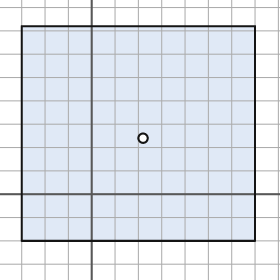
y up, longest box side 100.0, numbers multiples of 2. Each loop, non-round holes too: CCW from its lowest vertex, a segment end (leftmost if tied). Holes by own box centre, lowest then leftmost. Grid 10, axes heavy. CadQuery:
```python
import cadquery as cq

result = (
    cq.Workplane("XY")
    .moveTo(-30.0, -20.0)
    .lineTo(70.0, -20.0)
    .lineTo(70.0, 72.0)
    .lineTo(-30.0, 72.0)
    .close()
    .moveTo(22.0, 24.0)
    .circle(2.0)
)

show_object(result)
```